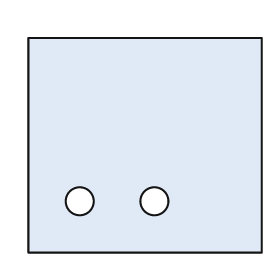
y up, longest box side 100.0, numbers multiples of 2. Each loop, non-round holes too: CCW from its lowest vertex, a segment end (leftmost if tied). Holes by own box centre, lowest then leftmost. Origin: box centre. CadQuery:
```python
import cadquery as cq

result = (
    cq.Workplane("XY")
    .moveTo(-50.0, -46.0)
    .lineTo(50.0, -46.0)
    .lineTo(50.0, 46.0)
    .lineTo(-50.0, 46.0)
    .close()
    .moveTo(-28.0, -24.0)
    .circle(6.0)
    .moveTo(4.0, -24.0)
    .circle(6.0)
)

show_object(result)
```